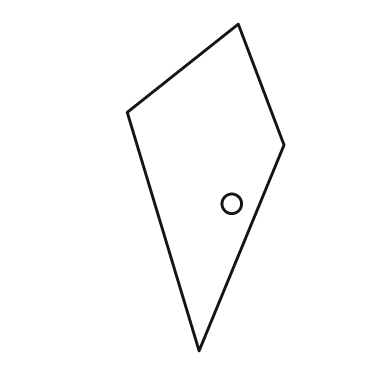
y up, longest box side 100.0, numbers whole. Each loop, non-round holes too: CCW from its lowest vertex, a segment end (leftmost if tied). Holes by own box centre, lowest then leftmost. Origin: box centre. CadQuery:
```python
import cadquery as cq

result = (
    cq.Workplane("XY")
    .moveTo(-2.0, -50.0)
    .lineTo(24.0, 13.0)
    .lineTo(10.0, 50.0)
    .lineTo(-24.0, 23.0)
    .close()
    .moveTo(8.0, -5.0)
    .circle(3.0)
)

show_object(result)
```